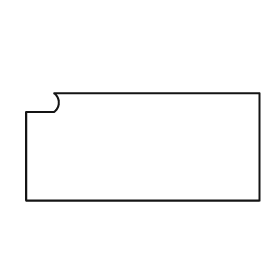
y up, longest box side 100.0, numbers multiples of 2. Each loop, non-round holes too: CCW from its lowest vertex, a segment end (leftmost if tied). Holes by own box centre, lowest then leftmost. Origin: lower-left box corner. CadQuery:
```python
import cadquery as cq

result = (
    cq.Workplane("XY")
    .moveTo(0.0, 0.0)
    .lineTo(100.0, 0.0)
    .lineTo(100.0, 46.0)
    .lineTo(12.0, 46.0)
    .threePointArc((14.0, 42.0), (12.0, 38.0))
    .lineTo(0.0, 38.0)
    .close()
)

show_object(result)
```